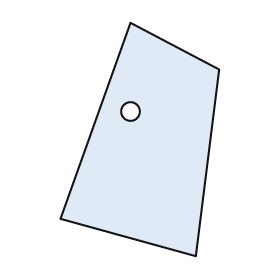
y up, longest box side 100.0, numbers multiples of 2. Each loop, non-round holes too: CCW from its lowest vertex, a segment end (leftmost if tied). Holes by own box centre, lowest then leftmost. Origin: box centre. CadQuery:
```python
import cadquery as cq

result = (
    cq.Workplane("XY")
    .moveTo(24.0, -50.0)
    .lineTo(34.0, 30.0)
    .lineTo(-4.0, 50.0)
    .lineTo(-34.0, -34.0)
    .close()
    .moveTo(-4.0, 12.0)
    .circle(4.0)
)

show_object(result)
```